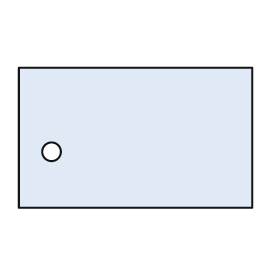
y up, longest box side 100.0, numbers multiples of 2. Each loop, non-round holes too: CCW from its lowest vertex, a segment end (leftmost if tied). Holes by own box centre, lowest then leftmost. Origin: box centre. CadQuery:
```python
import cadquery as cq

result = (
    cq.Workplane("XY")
    .moveTo(-50.0, -30.0)
    .lineTo(50.0, -30.0)
    .lineTo(50.0, 30.0)
    .lineTo(-50.0, 30.0)
    .close()
    .moveTo(-36.0, -6.0)
    .circle(4.0)
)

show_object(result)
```